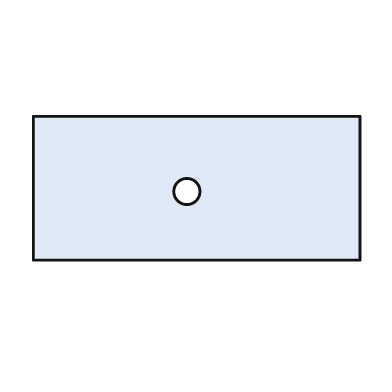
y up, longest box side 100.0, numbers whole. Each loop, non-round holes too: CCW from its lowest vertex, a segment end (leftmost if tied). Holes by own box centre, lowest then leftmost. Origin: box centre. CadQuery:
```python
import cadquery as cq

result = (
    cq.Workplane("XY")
    .moveTo(-50.0, -22.0)
    .lineTo(50.0, -22.0)
    .lineTo(50.0, 22.0)
    .lineTo(-50.0, 22.0)
    .close()
    .moveTo(-3.0, -1.0)
    .circle(4.0)
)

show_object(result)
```